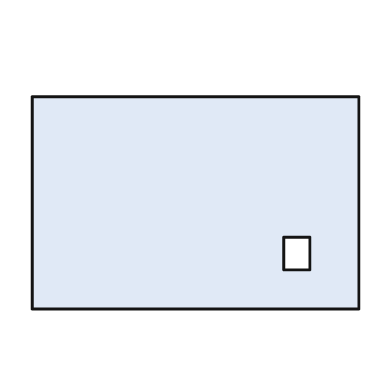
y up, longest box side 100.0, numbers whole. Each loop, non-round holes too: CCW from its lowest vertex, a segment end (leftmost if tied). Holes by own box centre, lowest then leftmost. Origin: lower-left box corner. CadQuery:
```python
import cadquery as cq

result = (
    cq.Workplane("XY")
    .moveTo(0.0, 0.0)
    .lineTo(100.0, 0.0)
    .lineTo(100.0, 65.0)
    .lineTo(0.0, 65.0)
    .close()
    .moveTo(77.0, 12.0)
    .lineTo(85.0, 12.0)
    .lineTo(85.0, 22.0)
    .lineTo(77.0, 22.0)
    .close()
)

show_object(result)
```